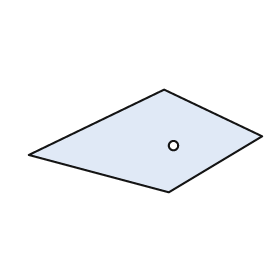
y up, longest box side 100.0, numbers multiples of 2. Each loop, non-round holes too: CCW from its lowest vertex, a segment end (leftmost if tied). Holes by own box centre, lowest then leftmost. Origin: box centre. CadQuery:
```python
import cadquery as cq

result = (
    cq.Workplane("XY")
    .moveTo(10.0, -22.0)
    .lineTo(50.0, 2.0)
    .lineTo(8.0, 22.0)
    .lineTo(-50.0, -6.0)
    .close()
    .moveTo(12.0, -2.0)
    .circle(2.0)
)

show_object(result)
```